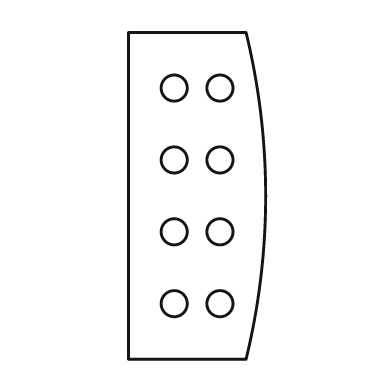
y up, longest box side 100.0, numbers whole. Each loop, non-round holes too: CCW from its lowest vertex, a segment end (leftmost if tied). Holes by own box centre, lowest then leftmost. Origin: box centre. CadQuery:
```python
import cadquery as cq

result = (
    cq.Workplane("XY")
    .moveTo(-21.0, -50.0)
    .lineTo(15.0, -50.0)
    .threePointArc((21.0, 0.0), (15.0, 50.0))
    .lineTo(-21.0, 50.0)
    .close()
    .moveTo(-7.0, -33.0)
    .circle(4.0)
    .moveTo(7.0, -33.0)
    .circle(4.0)
    .moveTo(-7.0, -11.0)
    .circle(4.0)
    .moveTo(7.0, -11.0)
    .circle(4.0)
    .moveTo(-7.0, 11.0)
    .circle(4.0)
    .moveTo(7.0, 11.0)
    .circle(4.0)
    .moveTo(-7.0, 33.0)
    .circle(4.0)
    .moveTo(7.0, 33.0)
    .circle(4.0)
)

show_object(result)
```